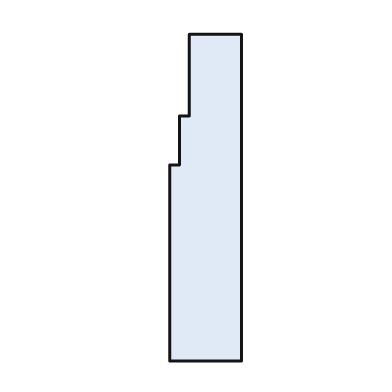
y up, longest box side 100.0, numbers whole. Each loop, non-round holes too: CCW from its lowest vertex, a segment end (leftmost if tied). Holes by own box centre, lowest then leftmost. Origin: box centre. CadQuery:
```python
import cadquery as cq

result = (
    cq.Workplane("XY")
    .moveTo(-11.0, -50.0)
    .lineTo(11.0, -50.0)
    .lineTo(11.0, 50.0)
    .lineTo(-5.0, 50.0)
    .lineTo(-5.0, 25.0)
    .lineTo(-8.0, 25.0)
    .lineTo(-8.0, 10.0)
    .lineTo(-11.0, 10.0)
    .close()
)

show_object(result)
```